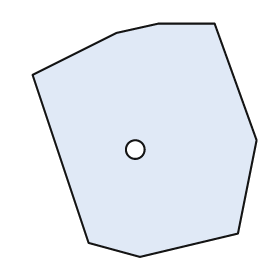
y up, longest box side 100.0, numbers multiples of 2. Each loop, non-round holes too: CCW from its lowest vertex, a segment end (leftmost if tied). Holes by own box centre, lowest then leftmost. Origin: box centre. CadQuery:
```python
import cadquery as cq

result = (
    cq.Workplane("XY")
    .moveTo(-2.0, -50.0)
    .lineTo(40.0, -40.0)
    .lineTo(48.0, 0.0)
    .lineTo(30.0, 50.0)
    .lineTo(6.0, 50.0)
    .lineTo(-12.0, 46.0)
    .lineTo(-48.0, 28.0)
    .lineTo(-24.0, -44.0)
    .close()
    .moveTo(-4.0, -4.0)
    .circle(4.0)
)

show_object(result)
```